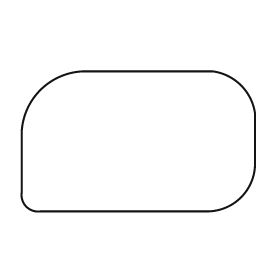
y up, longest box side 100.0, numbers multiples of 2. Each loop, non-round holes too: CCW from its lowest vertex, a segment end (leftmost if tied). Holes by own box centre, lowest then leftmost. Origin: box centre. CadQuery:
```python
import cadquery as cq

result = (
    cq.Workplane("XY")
    .moveTo(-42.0, -30.0)
    .lineTo(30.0, -30.0)
    .threePointArc((44.0, -24.0), (50.0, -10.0))
    .lineTo(50.0, 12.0)
    .threePointArc((44.0, 24.0), (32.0, 30.0))
    .lineTo(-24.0, 30.0)
    .threePointArc((-42.0, 22.0), (-50.0, 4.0))
    .lineTo(-50.0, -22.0)
    .threePointArc((-48.0, -28.0), (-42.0, -30.0))
    .close()
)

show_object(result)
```